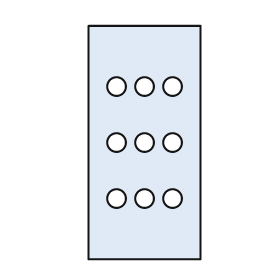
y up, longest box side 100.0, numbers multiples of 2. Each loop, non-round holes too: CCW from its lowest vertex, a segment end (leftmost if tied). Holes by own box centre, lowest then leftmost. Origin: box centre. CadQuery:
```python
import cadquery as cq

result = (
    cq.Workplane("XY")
    .moveTo(-24.0, -50.0)
    .lineTo(24.0, -50.0)
    .lineTo(24.0, 50.0)
    .lineTo(-24.0, 50.0)
    .close()
    .moveTo(-12.0, -24.0)
    .circle(4.0)
    .moveTo(0.0, -24.0)
    .circle(4.0)
    .moveTo(12.0, -24.0)
    .circle(4.0)
    .moveTo(-12.0, 0.0)
    .circle(4.0)
    .moveTo(0.0, 0.0)
    .circle(4.0)
    .moveTo(12.0, 0.0)
    .circle(4.0)
    .moveTo(-12.0, 24.0)
    .circle(4.0)
    .moveTo(0.0, 24.0)
    .circle(4.0)
    .moveTo(12.0, 24.0)
    .circle(4.0)
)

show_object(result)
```